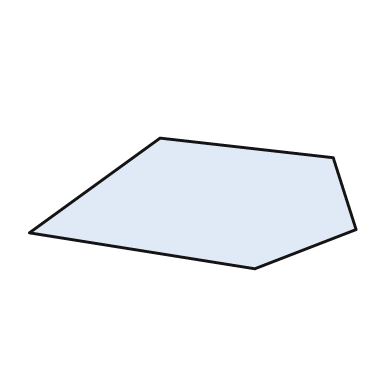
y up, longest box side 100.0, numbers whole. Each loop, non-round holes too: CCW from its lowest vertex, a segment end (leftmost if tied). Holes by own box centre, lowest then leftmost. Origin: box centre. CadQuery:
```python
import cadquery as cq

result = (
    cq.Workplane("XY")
    .moveTo(19.0, -20.0)
    .lineTo(50.0, -8.0)
    .lineTo(43.0, 14.0)
    .lineTo(-10.0, 20.0)
    .lineTo(-50.0, -9.0)
    .close()
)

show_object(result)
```